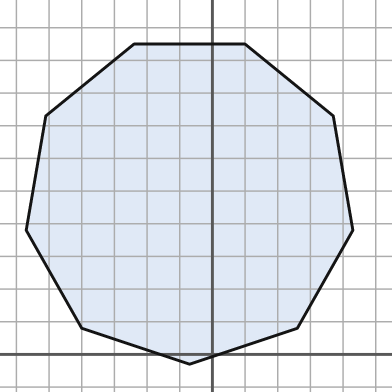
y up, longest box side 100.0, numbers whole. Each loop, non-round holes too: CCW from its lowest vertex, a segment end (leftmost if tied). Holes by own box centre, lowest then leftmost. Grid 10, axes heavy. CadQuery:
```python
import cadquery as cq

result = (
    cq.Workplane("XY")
    .moveTo(-7.0, -3.0)
    .lineTo(26.0, 8.0)
    .lineTo(43.0, 38.0)
    .lineTo(37.0, 73.0)
    .lineTo(10.0, 95.0)
    .lineTo(-24.0, 95.0)
    .lineTo(-51.0, 73.0)
    .lineTo(-57.0, 38.0)
    .lineTo(-40.0, 8.0)
    .close()
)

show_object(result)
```